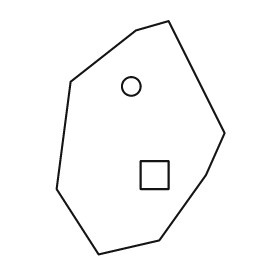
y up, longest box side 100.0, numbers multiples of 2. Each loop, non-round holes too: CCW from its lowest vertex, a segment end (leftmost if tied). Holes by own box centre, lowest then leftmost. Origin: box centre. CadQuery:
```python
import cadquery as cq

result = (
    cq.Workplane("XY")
    .moveTo(-18.0, -50.0)
    .lineTo(8.0, -44.0)
    .lineTo(28.0, -16.0)
    .lineTo(36.0, 2.0)
    .lineTo(12.0, 50.0)
    .lineTo(-2.0, 46.0)
    .lineTo(-30.0, 24.0)
    .lineTo(-36.0, -22.0)
    .close()
    .moveTo(0.0, -22.0)
    .lineTo(12.0, -22.0)
    .lineTo(12.0, -10.0)
    .lineTo(0.0, -10.0)
    .close()
    .moveTo(-4.0, 22.0)
    .circle(4.0)
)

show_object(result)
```